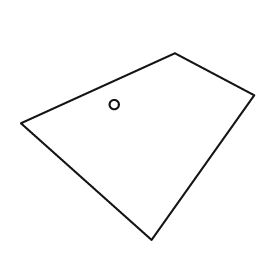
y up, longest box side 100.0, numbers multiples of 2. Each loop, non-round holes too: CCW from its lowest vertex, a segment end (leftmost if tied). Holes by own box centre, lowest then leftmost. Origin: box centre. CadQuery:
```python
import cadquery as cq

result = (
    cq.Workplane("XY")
    .moveTo(6.0, -40.0)
    .lineTo(50.0, 22.0)
    .lineTo(16.0, 40.0)
    .lineTo(-50.0, 10.0)
    .close()
    .moveTo(-10.0, 18.0)
    .circle(2.0)
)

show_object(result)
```